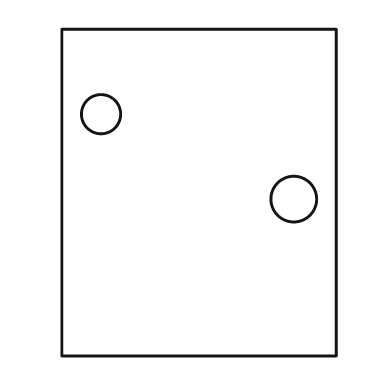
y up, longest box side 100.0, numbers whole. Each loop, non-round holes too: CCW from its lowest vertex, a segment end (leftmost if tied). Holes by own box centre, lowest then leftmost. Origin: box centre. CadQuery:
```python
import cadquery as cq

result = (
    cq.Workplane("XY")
    .moveTo(-42.0, -50.0)
    .lineTo(42.0, -50.0)
    .lineTo(42.0, 50.0)
    .lineTo(-42.0, 50.0)
    .close()
    .moveTo(29.0, -2.0)
    .circle(7.0)
    .moveTo(-30.0, 24.0)
    .circle(6.0)
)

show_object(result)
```